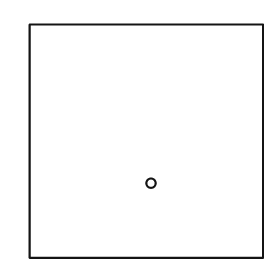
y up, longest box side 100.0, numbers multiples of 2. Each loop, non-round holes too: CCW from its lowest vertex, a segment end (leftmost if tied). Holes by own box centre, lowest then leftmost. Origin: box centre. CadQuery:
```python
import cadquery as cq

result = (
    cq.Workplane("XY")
    .moveTo(-50.0, -50.0)
    .lineTo(50.0, -50.0)
    .lineTo(50.0, 50.0)
    .lineTo(-50.0, 50.0)
    .close()
    .moveTo(2.0, -18.0)
    .circle(2.0)
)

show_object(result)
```